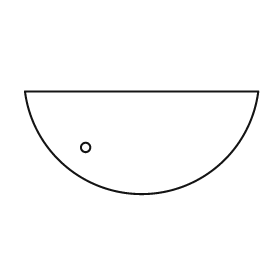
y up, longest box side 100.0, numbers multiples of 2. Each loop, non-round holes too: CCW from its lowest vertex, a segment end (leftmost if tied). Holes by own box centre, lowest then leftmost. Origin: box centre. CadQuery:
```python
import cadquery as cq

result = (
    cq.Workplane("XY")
    .moveTo(-50.0, 22.0)
    .threePointArc((0.0, -22.0), (50.0, 22.0))
    .close()
    .moveTo(-24.0, -2.0)
    .circle(2.0)
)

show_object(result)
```